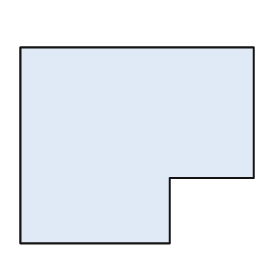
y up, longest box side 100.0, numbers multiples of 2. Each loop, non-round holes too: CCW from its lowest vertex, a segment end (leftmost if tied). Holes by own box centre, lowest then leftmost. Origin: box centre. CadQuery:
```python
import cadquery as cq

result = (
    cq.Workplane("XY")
    .moveTo(-50.0, -42.0)
    .lineTo(14.0, -42.0)
    .lineTo(14.0, -14.0)
    .lineTo(50.0, -14.0)
    .lineTo(50.0, 42.0)
    .lineTo(-50.0, 42.0)
    .close()
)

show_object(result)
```